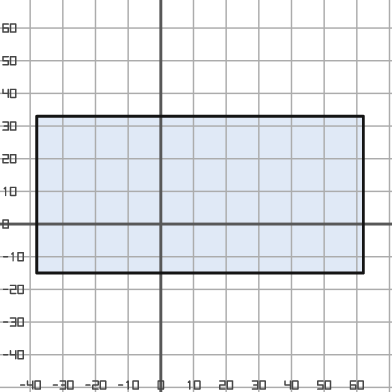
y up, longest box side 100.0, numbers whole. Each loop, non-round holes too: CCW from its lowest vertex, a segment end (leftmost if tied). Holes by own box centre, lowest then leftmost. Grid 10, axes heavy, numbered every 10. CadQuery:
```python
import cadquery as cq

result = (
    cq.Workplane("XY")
    .moveTo(-38.0, -15.0)
    .lineTo(62.0, -15.0)
    .lineTo(62.0, 33.0)
    .lineTo(-38.0, 33.0)
    .close()
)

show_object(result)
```